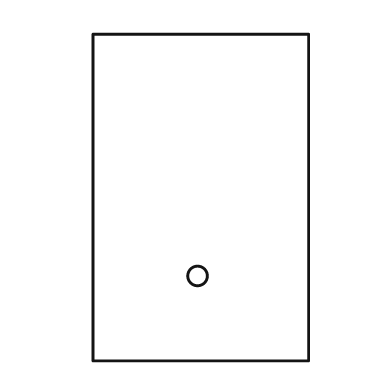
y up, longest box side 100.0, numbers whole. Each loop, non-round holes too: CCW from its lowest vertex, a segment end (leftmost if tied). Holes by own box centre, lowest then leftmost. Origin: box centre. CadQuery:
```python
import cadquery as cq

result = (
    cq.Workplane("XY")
    .moveTo(-33.0, -50.0)
    .lineTo(33.0, -50.0)
    .lineTo(33.0, 50.0)
    .lineTo(-33.0, 50.0)
    .close()
    .moveTo(-1.0, -24.0)
    .circle(3.0)
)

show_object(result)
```